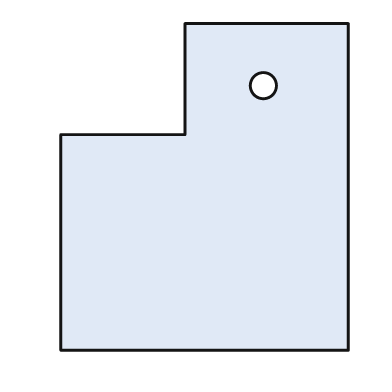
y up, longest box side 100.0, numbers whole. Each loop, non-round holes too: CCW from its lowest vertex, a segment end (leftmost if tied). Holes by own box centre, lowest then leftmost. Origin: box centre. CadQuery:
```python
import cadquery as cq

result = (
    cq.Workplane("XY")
    .moveTo(-44.0, -50.0)
    .lineTo(44.0, -50.0)
    .lineTo(44.0, 50.0)
    .lineTo(-6.0, 50.0)
    .lineTo(-6.0, 16.0)
    .lineTo(-44.0, 16.0)
    .close()
    .moveTo(18.0, 31.0)
    .circle(4.0)
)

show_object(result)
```